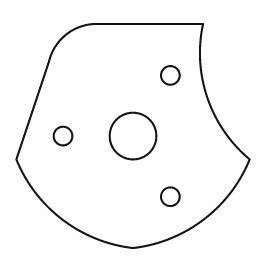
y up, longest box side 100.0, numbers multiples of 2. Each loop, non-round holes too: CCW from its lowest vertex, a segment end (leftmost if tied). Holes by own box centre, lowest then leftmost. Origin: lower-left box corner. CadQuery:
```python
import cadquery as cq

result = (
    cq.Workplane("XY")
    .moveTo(50.0, 0.0)
    .threePointArc((80.0, 12.0), (100.0, 38.0))
    .threePointArc((82.0, 64.0), (80.0, 96.0))
    .lineTo(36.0, 96.0)
    .threePointArc((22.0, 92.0), (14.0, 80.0))
    .lineTo(0.0, 38.0)
    .threePointArc((20.0, 12.0), (50.0, 0.0))
    .close()
    .moveTo(66.0, 22.0)
    .circle(4.0)
    .moveTo(20.0, 48.0)
    .circle(4.0)
    .moveTo(50.0, 48.0)
    .circle(10.0)
    .moveTo(66.0, 74.0)
    .circle(4.0)
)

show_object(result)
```